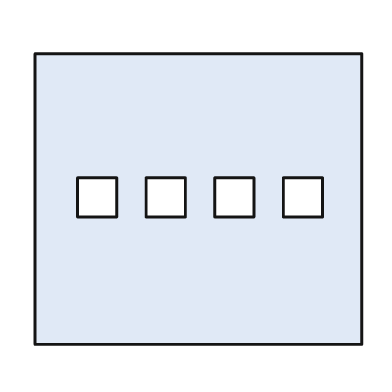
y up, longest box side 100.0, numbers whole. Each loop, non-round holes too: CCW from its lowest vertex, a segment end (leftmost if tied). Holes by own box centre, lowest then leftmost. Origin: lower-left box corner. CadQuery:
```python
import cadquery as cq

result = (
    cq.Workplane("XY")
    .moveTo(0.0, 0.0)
    .lineTo(100.0, 0.0)
    .lineTo(100.0, 89.0)
    .lineTo(0.0, 89.0)
    .close()
    .moveTo(13.0, 39.0)
    .lineTo(25.0, 39.0)
    .lineTo(25.0, 51.0)
    .lineTo(13.0, 51.0)
    .close()
    .moveTo(34.0, 39.0)
    .lineTo(46.0, 39.0)
    .lineTo(46.0, 51.0)
    .lineTo(34.0, 51.0)
    .close()
    .moveTo(55.0, 39.0)
    .lineTo(67.0, 39.0)
    .lineTo(67.0, 51.0)
    .lineTo(55.0, 51.0)
    .close()
    .moveTo(76.0, 39.0)
    .lineTo(88.0, 39.0)
    .lineTo(88.0, 51.0)
    .lineTo(76.0, 51.0)
    .close()
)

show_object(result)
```